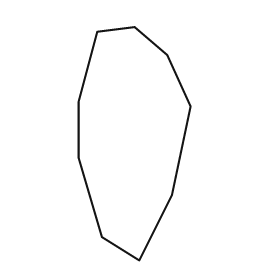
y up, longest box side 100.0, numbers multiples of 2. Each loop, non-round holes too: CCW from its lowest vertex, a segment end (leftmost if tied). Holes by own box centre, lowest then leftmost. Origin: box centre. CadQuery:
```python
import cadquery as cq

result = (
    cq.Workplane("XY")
    .moveTo(2.0, -50.0)
    .lineTo(16.0, -22.0)
    .lineTo(24.0, 16.0)
    .lineTo(14.0, 38.0)
    .lineTo(0.0, 50.0)
    .lineTo(-16.0, 48.0)
    .lineTo(-24.0, 18.0)
    .lineTo(-24.0, -6.0)
    .lineTo(-14.0, -40.0)
    .close()
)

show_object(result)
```